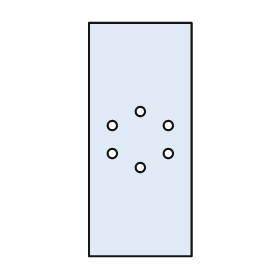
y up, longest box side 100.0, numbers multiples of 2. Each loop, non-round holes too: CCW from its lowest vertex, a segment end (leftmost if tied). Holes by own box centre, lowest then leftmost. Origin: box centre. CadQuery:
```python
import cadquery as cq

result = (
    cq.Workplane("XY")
    .moveTo(-22.0, -50.0)
    .lineTo(22.0, -50.0)
    .lineTo(22.0, 50.0)
    .lineTo(-22.0, 50.0)
    .close()
    .moveTo(0.0, -12.0)
    .circle(2.0)
    .moveTo(-12.0, -6.0)
    .circle(2.0)
    .moveTo(12.0, -6.0)
    .circle(2.0)
    .moveTo(-12.0, 6.0)
    .circle(2.0)
    .moveTo(12.0, 6.0)
    .circle(2.0)
    .moveTo(0.0, 12.0)
    .circle(2.0)
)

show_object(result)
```